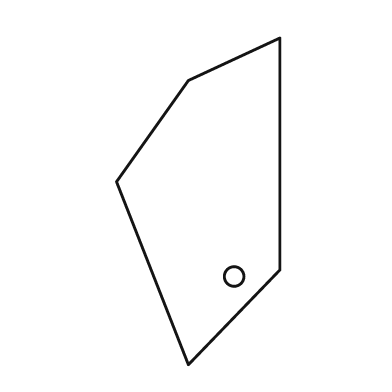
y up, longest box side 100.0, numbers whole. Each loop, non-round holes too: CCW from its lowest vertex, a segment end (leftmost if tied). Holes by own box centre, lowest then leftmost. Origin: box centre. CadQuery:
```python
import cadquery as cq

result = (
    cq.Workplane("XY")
    .moveTo(-3.0, -50.0)
    .lineTo(25.0, -21.0)
    .lineTo(25.0, 50.0)
    .lineTo(-3.0, 37.0)
    .lineTo(-25.0, 6.0)
    .close()
    .moveTo(11.0, -23.0)
    .circle(3.0)
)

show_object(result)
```